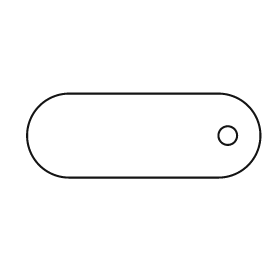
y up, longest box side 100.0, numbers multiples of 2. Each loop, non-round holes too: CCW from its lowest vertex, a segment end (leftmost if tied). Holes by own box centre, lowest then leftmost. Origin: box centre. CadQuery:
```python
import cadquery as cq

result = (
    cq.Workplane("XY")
    .moveTo(-32.0, -18.0)
    .lineTo(32.0, -18.0)
    .threePointArc((50.0, 0.0), (32.0, 18.0))
    .lineTo(-32.0, 18.0)
    .threePointArc((-50.0, 0.0), (-32.0, -18.0))
    .close()
    .moveTo(36.0, 0.0)
    .circle(4.0)
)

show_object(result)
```